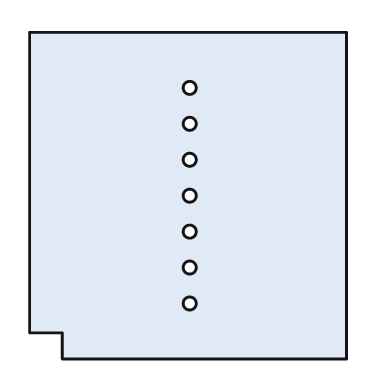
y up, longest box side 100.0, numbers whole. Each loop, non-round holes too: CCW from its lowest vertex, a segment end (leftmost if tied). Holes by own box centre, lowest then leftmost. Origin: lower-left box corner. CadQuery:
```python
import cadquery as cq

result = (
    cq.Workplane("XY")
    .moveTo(10.0, 0.0)
    .lineTo(97.0, 0.0)
    .lineTo(97.0, 100.0)
    .lineTo(0.0, 100.0)
    .lineTo(0.0, 8.0)
    .lineTo(10.0, 8.0)
    .close()
    .moveTo(49.0, 17.0)
    .circle(2.0)
    .moveTo(49.0, 28.0)
    .circle(2.0)
    .moveTo(49.0, 39.0)
    .circle(2.0)
    .moveTo(49.0, 50.0)
    .circle(2.0)
    .moveTo(49.0, 61.0)
    .circle(2.0)
    .moveTo(49.0, 72.0)
    .circle(2.0)
    .moveTo(49.0, 83.0)
    .circle(2.0)
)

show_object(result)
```